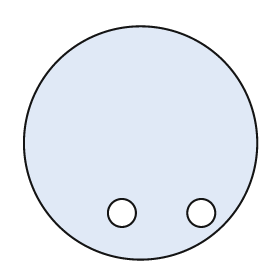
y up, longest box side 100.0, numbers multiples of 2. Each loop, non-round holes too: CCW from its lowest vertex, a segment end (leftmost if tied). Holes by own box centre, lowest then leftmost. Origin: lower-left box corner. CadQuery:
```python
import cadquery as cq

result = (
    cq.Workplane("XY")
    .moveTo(50.0, 50.0)
    .circle(50.0)
    .moveTo(42.0, 20.0)
    .circle(6.0)
    .moveTo(76.0, 20.0)
    .circle(6.0)
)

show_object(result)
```